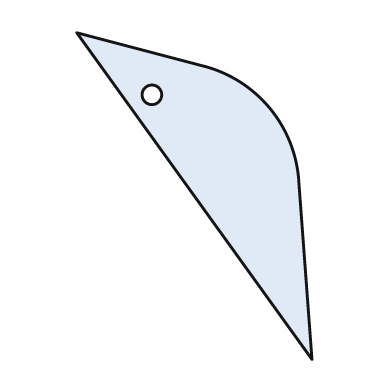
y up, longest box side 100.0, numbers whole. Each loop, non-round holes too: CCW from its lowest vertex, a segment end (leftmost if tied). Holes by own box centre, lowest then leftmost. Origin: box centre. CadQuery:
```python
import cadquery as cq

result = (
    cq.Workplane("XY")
    .moveTo(36.0, -50.0)
    .lineTo(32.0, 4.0)
    .threePointArc((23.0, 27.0), (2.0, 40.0))
    .lineTo(-36.0, 50.0)
    .close()
    .moveTo(-13.0, 31.0)
    .circle(3.0)
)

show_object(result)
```